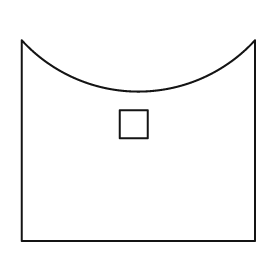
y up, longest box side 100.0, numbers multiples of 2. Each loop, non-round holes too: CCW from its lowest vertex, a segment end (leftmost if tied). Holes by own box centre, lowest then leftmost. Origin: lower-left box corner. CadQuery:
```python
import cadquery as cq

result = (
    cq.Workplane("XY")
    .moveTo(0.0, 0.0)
    .lineTo(100.0, 0.0)
    .lineTo(100.0, 86.0)
    .threePointArc((50.0, 64.0), (0.0, 86.0))
    .close()
    .moveTo(42.0, 44.0)
    .lineTo(54.0, 44.0)
    .lineTo(54.0, 56.0)
    .lineTo(42.0, 56.0)
    .close()
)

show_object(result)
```